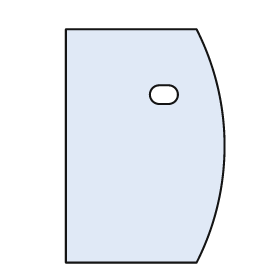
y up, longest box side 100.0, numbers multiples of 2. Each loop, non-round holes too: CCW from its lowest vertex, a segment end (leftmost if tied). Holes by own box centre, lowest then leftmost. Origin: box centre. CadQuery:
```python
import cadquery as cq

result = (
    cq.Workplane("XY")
    .moveTo(-34.0, -50.0)
    .lineTo(22.0, -50.0)
    .threePointArc((34.0, 0.0), (22.0, 50.0))
    .lineTo(-34.0, 50.0)
    .close()
    .moveTo(6.0, 18.0)
    .lineTo(10.0, 18.0)
    .threePointArc((14.0, 22.0), (10.0, 26.0))
    .lineTo(6.0, 26.0)
    .threePointArc((2.0, 22.0), (6.0, 18.0))
    .close()
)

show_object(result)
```